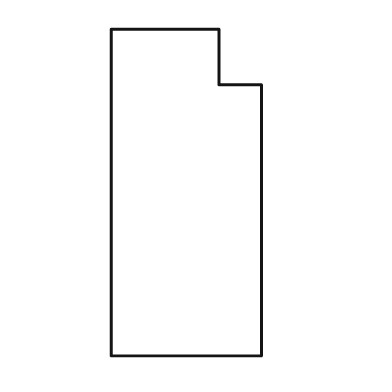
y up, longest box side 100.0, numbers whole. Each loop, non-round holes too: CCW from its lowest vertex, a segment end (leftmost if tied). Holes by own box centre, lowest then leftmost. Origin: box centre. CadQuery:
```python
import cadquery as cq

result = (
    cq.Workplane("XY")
    .moveTo(-23.0, -50.0)
    .lineTo(23.0, -50.0)
    .lineTo(23.0, 33.0)
    .lineTo(10.0, 33.0)
    .lineTo(10.0, 50.0)
    .lineTo(-23.0, 50.0)
    .close()
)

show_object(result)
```